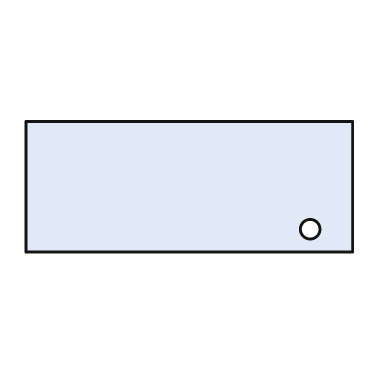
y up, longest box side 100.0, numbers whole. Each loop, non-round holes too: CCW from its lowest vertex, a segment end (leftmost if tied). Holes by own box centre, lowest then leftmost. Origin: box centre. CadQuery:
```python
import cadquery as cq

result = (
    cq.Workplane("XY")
    .moveTo(-50.0, -20.0)
    .lineTo(50.0, -20.0)
    .lineTo(50.0, 20.0)
    .lineTo(-50.0, 20.0)
    .close()
    .moveTo(37.0, -13.0)
    .circle(3.0)
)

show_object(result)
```